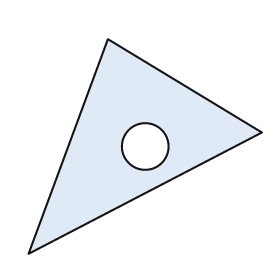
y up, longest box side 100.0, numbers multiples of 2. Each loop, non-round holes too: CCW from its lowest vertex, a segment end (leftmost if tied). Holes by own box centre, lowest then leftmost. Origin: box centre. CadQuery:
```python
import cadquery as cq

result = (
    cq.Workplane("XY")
    .moveTo(-50.0, -46.0)
    .lineTo(50.0, 6.0)
    .lineTo(-16.0, 46.0)
    .close()
    .moveTo(0.0, 0.0)
    .circle(10.0)
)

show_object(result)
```